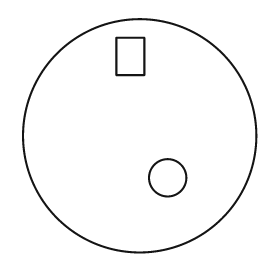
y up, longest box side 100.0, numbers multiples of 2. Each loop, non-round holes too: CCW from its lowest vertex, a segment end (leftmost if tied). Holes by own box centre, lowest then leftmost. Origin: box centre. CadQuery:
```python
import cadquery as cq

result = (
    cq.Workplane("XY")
    .moveTo(0.0, 0.0)
    .circle(50.0)
    .moveTo(12.0, -18.0)
    .circle(8.0)
    .moveTo(-10.0, 26.0)
    .lineTo(2.0, 26.0)
    .lineTo(2.0, 42.0)
    .lineTo(-10.0, 42.0)
    .close()
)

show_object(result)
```